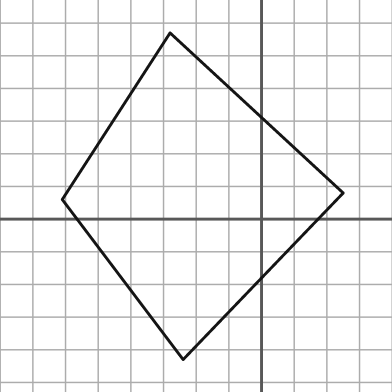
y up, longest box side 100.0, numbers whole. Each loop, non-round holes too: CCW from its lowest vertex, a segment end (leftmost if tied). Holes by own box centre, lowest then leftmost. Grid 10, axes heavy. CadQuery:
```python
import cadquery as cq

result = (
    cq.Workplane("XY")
    .moveTo(-24.0, -43.0)
    .lineTo(25.0, 8.0)
    .lineTo(-28.0, 57.0)
    .lineTo(-61.0, 6.0)
    .close()
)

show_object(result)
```